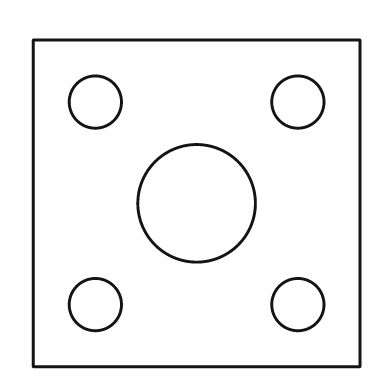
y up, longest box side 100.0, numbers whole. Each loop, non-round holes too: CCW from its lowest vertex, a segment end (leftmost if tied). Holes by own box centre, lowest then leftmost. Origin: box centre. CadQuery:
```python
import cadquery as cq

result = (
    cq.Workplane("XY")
    .moveTo(-50.0, -50.0)
    .lineTo(50.0, -50.0)
    .lineTo(50.0, 50.0)
    .lineTo(-50.0, 50.0)
    .close()
    .moveTo(-31.0, -31.0)
    .circle(8.0)
    .moveTo(31.0, -31.0)
    .circle(8.0)
    .moveTo(0.0, 0.0)
    .circle(18.0)
    .moveTo(-31.0, 31.0)
    .circle(8.0)
    .moveTo(31.0, 31.0)
    .circle(8.0)
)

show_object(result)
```